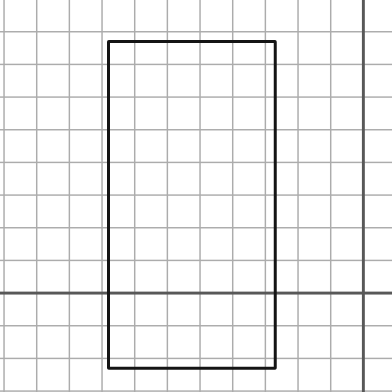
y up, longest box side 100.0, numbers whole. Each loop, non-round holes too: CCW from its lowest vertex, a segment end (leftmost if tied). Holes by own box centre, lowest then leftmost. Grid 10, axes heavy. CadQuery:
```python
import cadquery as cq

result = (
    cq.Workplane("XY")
    .moveTo(-78.0, -23.0)
    .lineTo(-27.0, -23.0)
    .lineTo(-27.0, 77.0)
    .lineTo(-78.0, 77.0)
    .close()
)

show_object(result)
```